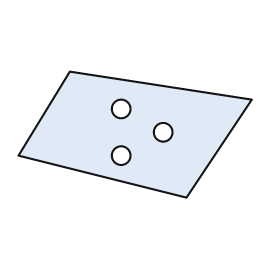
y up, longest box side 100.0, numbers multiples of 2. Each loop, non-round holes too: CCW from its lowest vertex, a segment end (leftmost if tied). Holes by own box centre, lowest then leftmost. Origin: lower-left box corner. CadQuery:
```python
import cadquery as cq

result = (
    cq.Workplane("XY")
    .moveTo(72.0, 0.0)
    .lineTo(100.0, 42.0)
    .lineTo(22.0, 54.0)
    .lineTo(0.0, 18.0)
    .close()
    .moveTo(44.0, 18.0)
    .circle(4.0)
    .moveTo(62.0, 28.0)
    .circle(4.0)
    .moveTo(44.0, 38.0)
    .circle(4.0)
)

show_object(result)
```